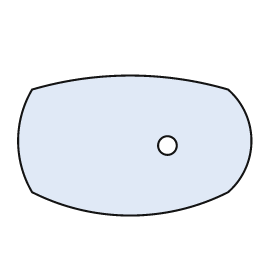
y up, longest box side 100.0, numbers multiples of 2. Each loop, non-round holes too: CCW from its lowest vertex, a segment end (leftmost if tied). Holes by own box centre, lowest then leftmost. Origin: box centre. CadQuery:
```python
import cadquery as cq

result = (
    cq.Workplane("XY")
    .moveTo(-44.0, -20.0)
    .threePointArc((-2.0, -30.0), (40.0, -20.0))
    .threePointArc((50.0, 2.0), (40.0, 24.0))
    .threePointArc((-2.0, 30.0), (-44.0, 24.0))
    .threePointArc((-50.0, 2.0), (-44.0, -20.0))
    .close()
    .moveTo(14.0, 0.0)
    .circle(4.0)
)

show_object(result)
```